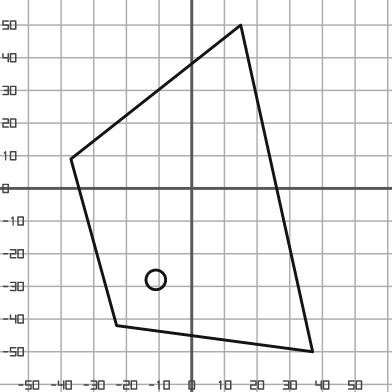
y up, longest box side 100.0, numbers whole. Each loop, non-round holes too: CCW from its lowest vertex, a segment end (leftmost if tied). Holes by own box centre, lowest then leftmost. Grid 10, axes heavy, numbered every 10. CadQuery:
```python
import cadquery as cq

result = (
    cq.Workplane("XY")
    .moveTo(37.0, -50.0)
    .lineTo(15.0, 50.0)
    .lineTo(-37.0, 9.0)
    .lineTo(-23.0, -42.0)
    .close()
    .moveTo(-11.0, -28.0)
    .circle(3.0)
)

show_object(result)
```